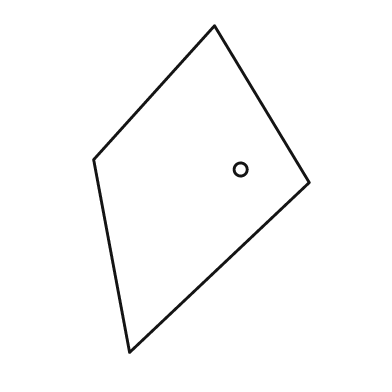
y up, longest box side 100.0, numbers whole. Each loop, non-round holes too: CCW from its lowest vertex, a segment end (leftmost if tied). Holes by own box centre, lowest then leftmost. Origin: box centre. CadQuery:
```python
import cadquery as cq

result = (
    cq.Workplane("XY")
    .moveTo(-22.0, -50.0)
    .lineTo(33.0, 2.0)
    .lineTo(4.0, 50.0)
    .lineTo(-33.0, 9.0)
    .close()
    .moveTo(12.0, 6.0)
    .circle(2.0)
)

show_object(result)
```